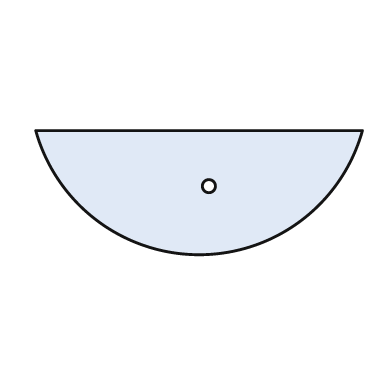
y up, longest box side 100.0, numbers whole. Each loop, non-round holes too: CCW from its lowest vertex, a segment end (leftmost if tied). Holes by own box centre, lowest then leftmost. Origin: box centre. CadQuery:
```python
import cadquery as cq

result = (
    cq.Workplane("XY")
    .moveTo(-50.0, 19.0)
    .threePointArc((0.0, -19.0), (50.0, 19.0))
    .close()
    .moveTo(3.0, 2.0)
    .circle(2.0)
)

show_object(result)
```